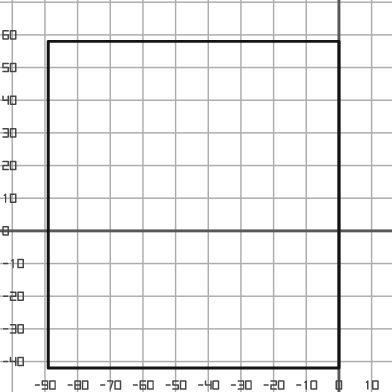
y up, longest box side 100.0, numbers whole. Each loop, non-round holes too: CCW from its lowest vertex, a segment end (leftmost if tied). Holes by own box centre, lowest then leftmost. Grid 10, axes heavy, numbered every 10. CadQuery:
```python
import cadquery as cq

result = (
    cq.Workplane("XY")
    .moveTo(-89.0, -42.0)
    .lineTo(0.0, -42.0)
    .lineTo(0.0, 58.0)
    .lineTo(-89.0, 58.0)
    .close()
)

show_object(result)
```